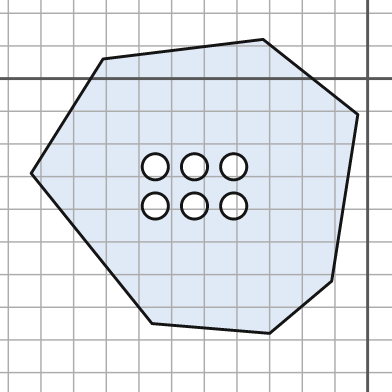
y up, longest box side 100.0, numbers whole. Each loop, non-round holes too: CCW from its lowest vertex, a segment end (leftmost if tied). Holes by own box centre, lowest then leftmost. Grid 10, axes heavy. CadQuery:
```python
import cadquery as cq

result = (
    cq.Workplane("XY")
    .moveTo(-30.0, -78.0)
    .lineTo(-11.0, -62.0)
    .lineTo(-3.0, -11.0)
    .lineTo(-32.0, 12.0)
    .lineTo(-81.0, 6.0)
    .lineTo(-103.0, -29.0)
    .lineTo(-66.0, -75.0)
    .close()
    .moveTo(-65.0, -39.0)
    .circle(4.0)
    .moveTo(-53.0, -39.0)
    .circle(4.0)
    .moveTo(-41.0, -39.0)
    .circle(4.0)
    .moveTo(-65.0, -27.0)
    .circle(4.0)
    .moveTo(-53.0, -27.0)
    .circle(4.0)
    .moveTo(-41.0, -27.0)
    .circle(4.0)
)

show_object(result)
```